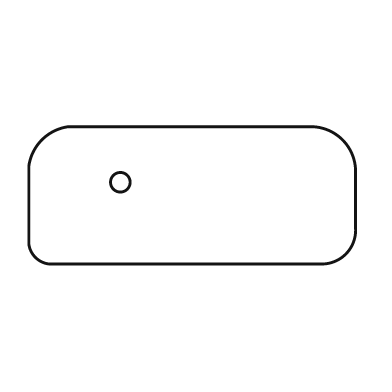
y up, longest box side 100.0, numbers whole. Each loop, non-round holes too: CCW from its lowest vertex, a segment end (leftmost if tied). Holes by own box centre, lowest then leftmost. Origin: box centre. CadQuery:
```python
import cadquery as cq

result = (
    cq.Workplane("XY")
    .moveTo(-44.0, -21.0)
    .lineTo(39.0, -21.0)
    .threePointArc((47.0, -18.0), (50.0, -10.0))
    .lineTo(50.0, 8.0)
    .threePointArc((46.0, 17.0), (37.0, 21.0))
    .lineTo(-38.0, 21.0)
    .threePointArc((-46.0, 17.0), (-50.0, 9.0))
    .lineTo(-50.0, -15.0)
    .threePointArc((-48.0, -19.0), (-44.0, -21.0))
    .close()
    .moveTo(-22.0, 4.0)
    .circle(3.0)
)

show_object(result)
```